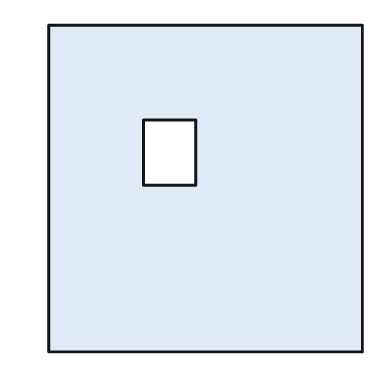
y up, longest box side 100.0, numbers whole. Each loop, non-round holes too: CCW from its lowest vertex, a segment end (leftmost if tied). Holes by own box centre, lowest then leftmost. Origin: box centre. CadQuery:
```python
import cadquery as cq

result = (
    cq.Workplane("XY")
    .moveTo(-48.0, -50.0)
    .lineTo(48.0, -50.0)
    .lineTo(48.0, 50.0)
    .lineTo(-48.0, 50.0)
    .close()
    .moveTo(-19.0, 1.0)
    .lineTo(-3.0, 1.0)
    .lineTo(-3.0, 21.0)
    .lineTo(-19.0, 21.0)
    .close()
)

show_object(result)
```